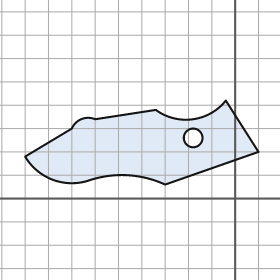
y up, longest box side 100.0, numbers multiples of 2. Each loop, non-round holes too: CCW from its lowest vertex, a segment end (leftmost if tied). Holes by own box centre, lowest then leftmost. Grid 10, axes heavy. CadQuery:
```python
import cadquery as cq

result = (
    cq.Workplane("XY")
    .moveTo(-30.0, 6.0)
    .lineTo(10.0, 20.0)
    .lineTo(-4.0, 42.0)
    .threePointArc((-18.0, 34.0), (-34.0, 38.0))
    .lineTo(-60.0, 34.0)
    .threePointArc((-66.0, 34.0), (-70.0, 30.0))
    .lineTo(-90.0, 18.0)
    .threePointArc((-78.0, 8.0), (-62.0, 8.0))
    .threePointArc((-46.0, 10.0), (-30.0, 6.0))
    .close()
    .moveTo(-18.0, 26.0)
    .circle(4.0)
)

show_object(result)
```